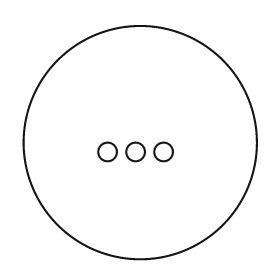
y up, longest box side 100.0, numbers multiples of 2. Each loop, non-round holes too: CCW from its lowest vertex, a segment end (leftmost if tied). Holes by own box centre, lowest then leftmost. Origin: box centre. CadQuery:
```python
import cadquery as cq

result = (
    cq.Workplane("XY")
    .moveTo(0.0, 0.0)
    .circle(50.0)
    .moveTo(-14.0, -4.0)
    .circle(4.0)
    .moveTo(-2.0, -4.0)
    .circle(4.0)
    .moveTo(10.0, -4.0)
    .circle(4.0)
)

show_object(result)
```